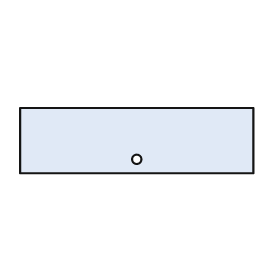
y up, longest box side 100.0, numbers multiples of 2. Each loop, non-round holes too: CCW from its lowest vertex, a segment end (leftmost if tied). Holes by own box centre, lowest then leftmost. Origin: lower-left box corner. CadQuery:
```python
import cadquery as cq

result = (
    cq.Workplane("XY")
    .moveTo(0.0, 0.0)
    .lineTo(100.0, 0.0)
    .lineTo(100.0, 28.0)
    .lineTo(0.0, 28.0)
    .close()
    .moveTo(50.0, 6.0)
    .circle(2.0)
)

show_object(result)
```